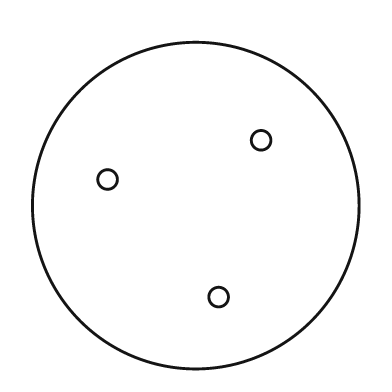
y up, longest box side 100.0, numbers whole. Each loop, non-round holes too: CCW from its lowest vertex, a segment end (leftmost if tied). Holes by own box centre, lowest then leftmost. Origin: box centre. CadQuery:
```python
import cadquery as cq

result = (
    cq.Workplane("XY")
    .moveTo(0.0, 0.0)
    .circle(50.0)
    .moveTo(7.0, -28.0)
    .circle(3.0)
    .moveTo(-27.0, 8.0)
    .circle(3.0)
    .moveTo(20.0, 20.0)
    .circle(3.0)
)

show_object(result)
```